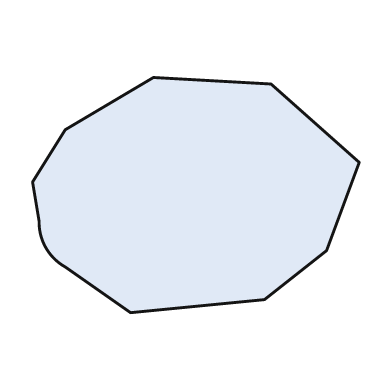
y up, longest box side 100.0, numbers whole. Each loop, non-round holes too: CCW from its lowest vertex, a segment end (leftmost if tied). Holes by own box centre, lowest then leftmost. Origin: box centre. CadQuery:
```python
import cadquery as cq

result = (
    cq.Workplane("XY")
    .moveTo(-20.0, -36.0)
    .lineTo(21.0, -32.0)
    .lineTo(40.0, -17.0)
    .lineTo(50.0, 10.0)
    .lineTo(23.0, 34.0)
    .lineTo(-13.0, 36.0)
    .lineTo(-40.0, 20.0)
    .lineTo(-50.0, 4.0)
    .lineTo(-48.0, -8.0)
    .threePointArc((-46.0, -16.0), (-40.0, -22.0))
    .close()
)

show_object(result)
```